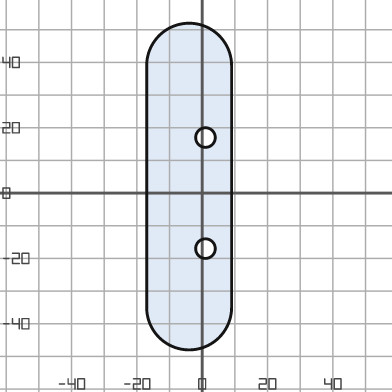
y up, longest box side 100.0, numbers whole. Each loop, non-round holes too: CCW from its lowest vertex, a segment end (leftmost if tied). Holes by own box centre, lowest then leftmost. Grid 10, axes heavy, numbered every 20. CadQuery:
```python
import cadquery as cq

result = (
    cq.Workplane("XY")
    .moveTo(-17.0, -35.0)
    .threePointArc((-4.0, -48.0), (9.0, -35.0))
    .lineTo(9.0, 39.0)
    .threePointArc((-4.0, 52.0), (-17.0, 39.0))
    .close()
    .moveTo(1.0, -17.0)
    .circle(3.0)
    .moveTo(1.0, 17.0)
    .circle(3.0)
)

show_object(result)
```